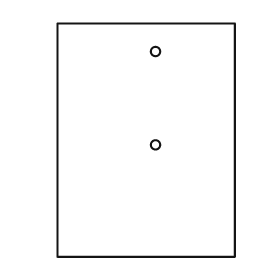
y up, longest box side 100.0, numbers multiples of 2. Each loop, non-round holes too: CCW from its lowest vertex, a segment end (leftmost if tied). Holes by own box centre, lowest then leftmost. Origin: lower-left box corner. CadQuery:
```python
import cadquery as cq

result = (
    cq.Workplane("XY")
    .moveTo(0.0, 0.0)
    .lineTo(76.0, 0.0)
    .lineTo(76.0, 100.0)
    .lineTo(0.0, 100.0)
    .close()
    .moveTo(42.0, 48.0)
    .circle(2.0)
    .moveTo(42.0, 88.0)
    .circle(2.0)
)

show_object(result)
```